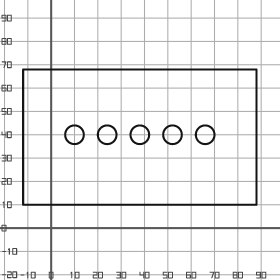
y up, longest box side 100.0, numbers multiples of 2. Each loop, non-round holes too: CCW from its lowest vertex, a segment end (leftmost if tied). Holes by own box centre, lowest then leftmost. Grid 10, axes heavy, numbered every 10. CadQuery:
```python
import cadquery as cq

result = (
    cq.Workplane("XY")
    .moveTo(-12.0, 10.0)
    .lineTo(88.0, 10.0)
    .lineTo(88.0, 68.0)
    .lineTo(-12.0, 68.0)
    .close()
    .moveTo(10.0, 40.0)
    .circle(4.0)
    .moveTo(24.0, 40.0)
    .circle(4.0)
    .moveTo(38.0, 40.0)
    .circle(4.0)
    .moveTo(52.0, 40.0)
    .circle(4.0)
    .moveTo(66.0, 40.0)
    .circle(4.0)
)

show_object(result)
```